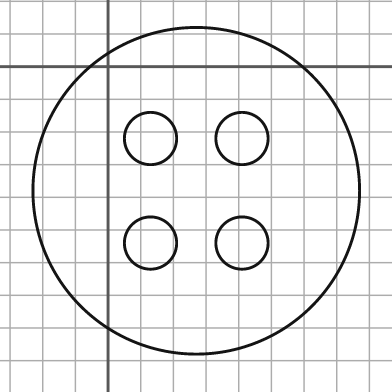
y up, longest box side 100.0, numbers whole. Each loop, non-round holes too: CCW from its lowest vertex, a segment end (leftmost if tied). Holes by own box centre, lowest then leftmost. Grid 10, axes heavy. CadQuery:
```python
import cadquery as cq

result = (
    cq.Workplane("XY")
    .moveTo(27.0, -38.0)
    .circle(50.0)
    .moveTo(13.0, -54.0)
    .circle(8.0)
    .moveTo(41.0, -54.0)
    .circle(8.0)
    .moveTo(13.0, -22.0)
    .circle(8.0)
    .moveTo(41.0, -22.0)
    .circle(8.0)
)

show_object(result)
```